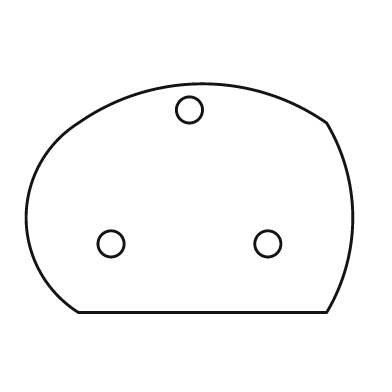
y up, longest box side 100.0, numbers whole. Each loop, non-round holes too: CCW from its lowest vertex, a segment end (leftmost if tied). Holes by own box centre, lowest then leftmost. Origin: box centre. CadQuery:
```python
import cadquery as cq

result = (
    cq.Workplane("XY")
    .moveTo(-34.0, -35.0)
    .lineTo(42.0, -35.0)
    .threePointArc((50.0, -6.0), (42.0, 23.0))
    .threePointArc((4.0, 35.0), (-34.0, 23.0))
    .threePointArc((-50.0, -6.0), (-34.0, -35.0))
    .close()
    .moveTo(-24.0, -14.0)
    .circle(4.0)
    .moveTo(24.0, -14.0)
    .circle(4.0)
    .moveTo(0.0, 27.0)
    .circle(4.0)
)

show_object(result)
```